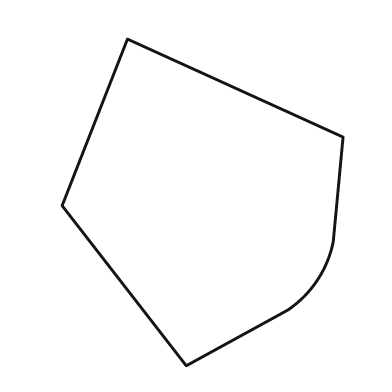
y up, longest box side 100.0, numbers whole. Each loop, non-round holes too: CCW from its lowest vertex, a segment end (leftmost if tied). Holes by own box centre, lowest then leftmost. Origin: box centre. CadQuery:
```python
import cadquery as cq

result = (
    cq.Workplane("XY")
    .moveTo(-5.0, -50.0)
    .lineTo(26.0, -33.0)
    .threePointArc((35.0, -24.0), (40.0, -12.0))
    .lineTo(43.0, 20.0)
    .lineTo(-23.0, 50.0)
    .lineTo(-43.0, -1.0)
    .close()
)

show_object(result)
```